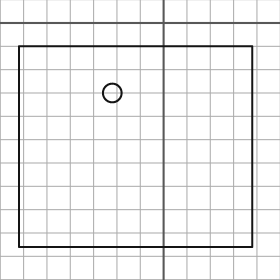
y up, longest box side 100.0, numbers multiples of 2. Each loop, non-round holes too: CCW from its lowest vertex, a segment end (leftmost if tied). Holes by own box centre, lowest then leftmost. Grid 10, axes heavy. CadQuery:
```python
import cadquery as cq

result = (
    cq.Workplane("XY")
    .moveTo(-62.0, -96.0)
    .lineTo(38.0, -96.0)
    .lineTo(38.0, -10.0)
    .lineTo(-62.0, -10.0)
    .close()
    .moveTo(-22.0, -30.0)
    .circle(4.0)
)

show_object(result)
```